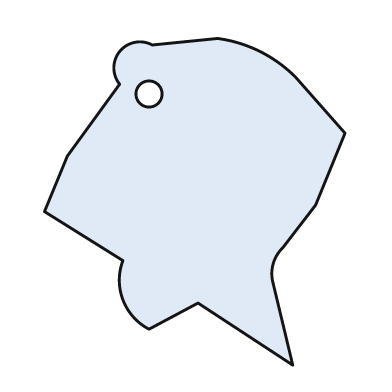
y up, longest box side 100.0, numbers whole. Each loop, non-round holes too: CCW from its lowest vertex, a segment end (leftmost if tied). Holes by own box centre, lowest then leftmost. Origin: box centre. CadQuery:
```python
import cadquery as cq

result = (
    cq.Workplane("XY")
    .moveTo(30.0, -50.0)
    .lineTo(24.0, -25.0)
    .threePointArc((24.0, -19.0), (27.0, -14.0))
    .lineTo(37.0, -1.0)
    .lineTo(46.0, 21.0)
    .lineTo(31.0, 38.0)
    .threePointArc((20.0, 46.0), (7.0, 50.0))
    .lineTo(-13.0, 48.0)
    .threePointArc((-23.0, 46.0), (-23.0, 36.0))
    .lineTo(-39.0, 14.0)
    .lineTo(-46.0, -3.0)
    .lineTo(-22.0, -18.0)
    .threePointArc((-22.0, -30.0), (-14.0, -39.0))
    .lineTo(1.0, -31.0)
    .close()
    .moveTo(-14.0, 33.0)
    .circle(4.0)
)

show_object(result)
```